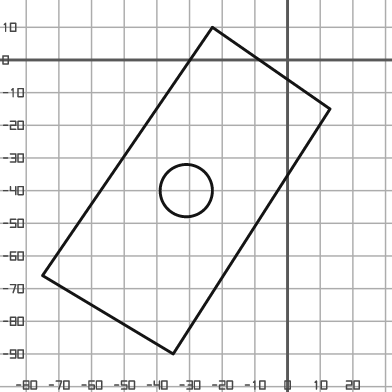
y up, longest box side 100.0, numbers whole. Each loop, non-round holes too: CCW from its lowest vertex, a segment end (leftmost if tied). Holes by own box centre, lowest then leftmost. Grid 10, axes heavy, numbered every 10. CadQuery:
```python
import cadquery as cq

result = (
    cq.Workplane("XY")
    .moveTo(-35.0, -90.0)
    .lineTo(13.0, -15.0)
    .lineTo(-23.0, 10.0)
    .lineTo(-75.0, -66.0)
    .close()
    .moveTo(-31.0, -40.0)
    .circle(8.0)
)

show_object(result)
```